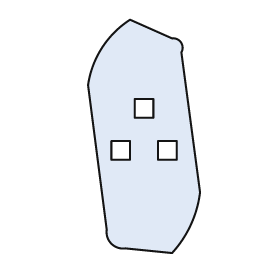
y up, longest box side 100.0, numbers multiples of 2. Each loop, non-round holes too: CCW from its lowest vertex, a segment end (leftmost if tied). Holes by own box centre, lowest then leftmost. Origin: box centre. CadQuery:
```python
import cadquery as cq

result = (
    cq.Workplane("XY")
    .moveTo(12.0, -50.0)
    .threePointArc((20.0, -38.0), (24.0, -24.0))
    .lineTo(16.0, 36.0)
    .threePointArc((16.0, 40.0), (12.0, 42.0))
    .lineTo(-6.0, 50.0)
    .threePointArc((-18.0, 38.0), (-24.0, 22.0))
    .lineTo(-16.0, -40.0)
    .threePointArc((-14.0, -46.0), (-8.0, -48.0))
    .close()
    .moveTo(-14.0, -10.0)
    .lineTo(-6.0, -10.0)
    .lineTo(-6.0, -2.0)
    .lineTo(-14.0, -2.0)
    .close()
    .moveTo(6.0, -10.0)
    .lineTo(14.0, -10.0)
    .lineTo(14.0, -2.0)
    .lineTo(6.0, -2.0)
    .close()
    .moveTo(-4.0, 8.0)
    .lineTo(4.0, 8.0)
    .lineTo(4.0, 16.0)
    .lineTo(-4.0, 16.0)
    .close()
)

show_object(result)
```